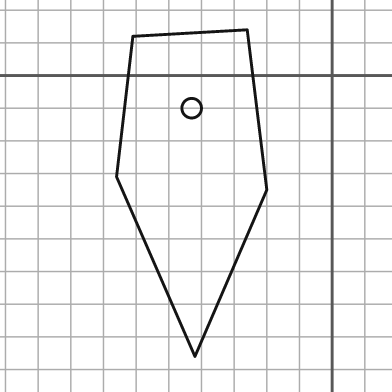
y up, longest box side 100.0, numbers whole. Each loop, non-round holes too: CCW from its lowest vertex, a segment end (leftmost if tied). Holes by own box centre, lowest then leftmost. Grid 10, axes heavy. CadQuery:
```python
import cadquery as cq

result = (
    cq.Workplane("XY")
    .moveTo(-42.0, -86.0)
    .lineTo(-20.0, -35.0)
    .lineTo(-26.0, 14.0)
    .lineTo(-61.0, 12.0)
    .lineTo(-66.0, -31.0)
    .close()
    .moveTo(-43.0, -10.0)
    .circle(3.0)
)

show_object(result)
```